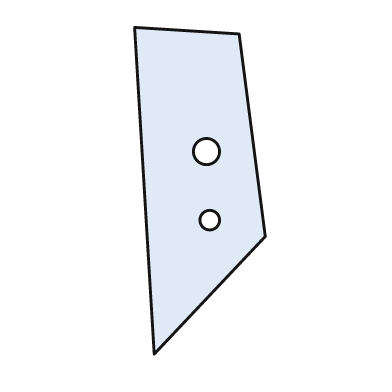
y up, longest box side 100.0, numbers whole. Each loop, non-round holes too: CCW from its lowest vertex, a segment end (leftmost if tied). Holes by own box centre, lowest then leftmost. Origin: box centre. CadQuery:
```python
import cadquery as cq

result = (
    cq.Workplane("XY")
    .moveTo(-14.0, -50.0)
    .lineTo(20.0, -14.0)
    .lineTo(12.0, 48.0)
    .lineTo(-20.0, 50.0)
    .close()
    .moveTo(3.0, -9.0)
    .circle(3.0)
    .moveTo(2.0, 12.0)
    .circle(4.0)
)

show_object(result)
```